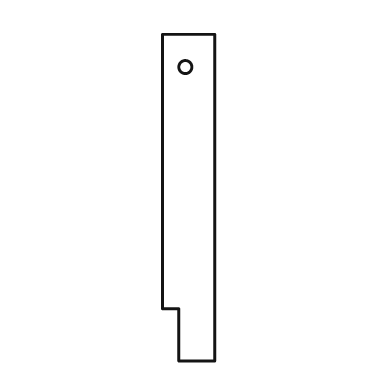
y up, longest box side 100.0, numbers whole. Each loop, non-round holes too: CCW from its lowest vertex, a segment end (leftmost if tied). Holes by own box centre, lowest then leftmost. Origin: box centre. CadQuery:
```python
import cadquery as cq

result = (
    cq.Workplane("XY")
    .moveTo(-3.0, -50.0)
    .lineTo(8.0, -50.0)
    .lineTo(8.0, 50.0)
    .lineTo(-8.0, 50.0)
    .lineTo(-8.0, -34.0)
    .lineTo(-3.0, -34.0)
    .close()
    .moveTo(-1.0, 40.0)
    .circle(2.0)
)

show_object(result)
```